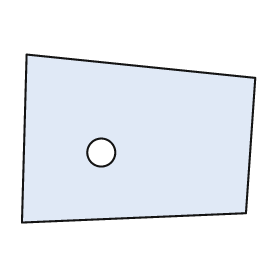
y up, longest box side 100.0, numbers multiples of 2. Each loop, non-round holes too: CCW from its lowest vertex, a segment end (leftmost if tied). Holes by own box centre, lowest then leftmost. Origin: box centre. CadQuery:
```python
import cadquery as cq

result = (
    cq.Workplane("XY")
    .moveTo(-50.0, -36.0)
    .lineTo(46.0, -32.0)
    .lineTo(50.0, 26.0)
    .lineTo(-48.0, 36.0)
    .close()
    .moveTo(-16.0, -6.0)
    .circle(6.0)
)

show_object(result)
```